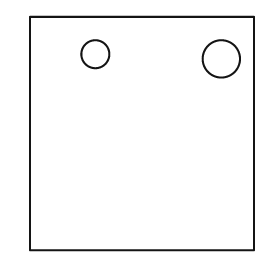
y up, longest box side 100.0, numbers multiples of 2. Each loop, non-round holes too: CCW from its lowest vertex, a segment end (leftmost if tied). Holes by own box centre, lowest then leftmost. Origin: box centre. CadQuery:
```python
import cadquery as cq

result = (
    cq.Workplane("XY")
    .moveTo(-48.0, -50.0)
    .lineTo(48.0, -50.0)
    .lineTo(48.0, 50.0)
    .lineTo(-48.0, 50.0)
    .close()
    .moveTo(34.0, 32.0)
    .circle(8.0)
    .moveTo(-20.0, 34.0)
    .circle(6.0)
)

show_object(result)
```